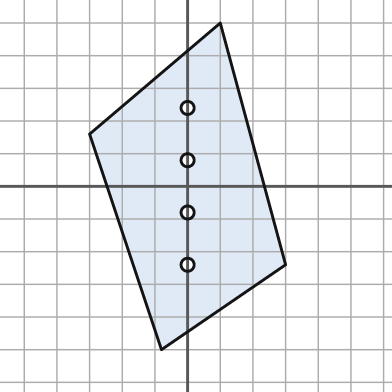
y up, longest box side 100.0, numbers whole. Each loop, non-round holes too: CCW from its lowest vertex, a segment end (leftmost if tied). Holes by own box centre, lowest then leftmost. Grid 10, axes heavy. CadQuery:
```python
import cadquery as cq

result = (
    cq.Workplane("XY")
    .moveTo(-8.0, -50.0)
    .lineTo(30.0, -24.0)
    .lineTo(10.0, 50.0)
    .lineTo(-30.0, 16.0)
    .close()
    .moveTo(0.0, -24.0)
    .circle(2.0)
    .moveTo(0.0, -8.0)
    .circle(2.0)
    .moveTo(0.0, 8.0)
    .circle(2.0)
    .moveTo(0.0, 24.0)
    .circle(2.0)
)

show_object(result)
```